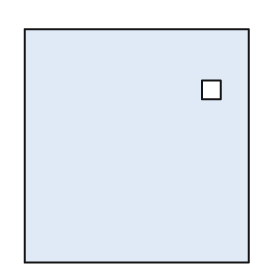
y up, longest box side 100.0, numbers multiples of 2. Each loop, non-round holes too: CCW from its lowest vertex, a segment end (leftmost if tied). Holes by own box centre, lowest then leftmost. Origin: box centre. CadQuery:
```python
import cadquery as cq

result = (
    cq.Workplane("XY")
    .moveTo(-48.0, -50.0)
    .lineTo(48.0, -50.0)
    .lineTo(48.0, 50.0)
    .lineTo(-48.0, 50.0)
    .close()
    .moveTo(28.0, 20.0)
    .lineTo(36.0, 20.0)
    .lineTo(36.0, 28.0)
    .lineTo(28.0, 28.0)
    .close()
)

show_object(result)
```